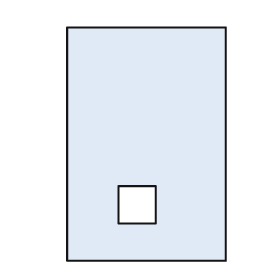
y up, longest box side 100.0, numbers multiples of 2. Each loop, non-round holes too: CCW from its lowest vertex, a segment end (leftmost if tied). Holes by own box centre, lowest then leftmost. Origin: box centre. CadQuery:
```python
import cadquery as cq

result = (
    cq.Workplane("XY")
    .moveTo(-34.0, -50.0)
    .lineTo(34.0, -50.0)
    .lineTo(34.0, 50.0)
    .lineTo(-34.0, 50.0)
    .close()
    .moveTo(-12.0, -34.0)
    .lineTo(4.0, -34.0)
    .lineTo(4.0, -18.0)
    .lineTo(-12.0, -18.0)
    .close()
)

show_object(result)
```